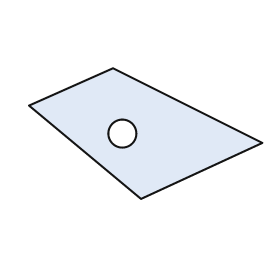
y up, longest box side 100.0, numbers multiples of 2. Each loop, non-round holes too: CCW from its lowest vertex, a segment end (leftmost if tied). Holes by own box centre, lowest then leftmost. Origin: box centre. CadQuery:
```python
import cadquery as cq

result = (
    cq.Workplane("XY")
    .moveTo(-2.0, -28.0)
    .lineTo(50.0, -4.0)
    .lineTo(-14.0, 28.0)
    .lineTo(-50.0, 12.0)
    .close()
    .moveTo(-10.0, 0.0)
    .circle(6.0)
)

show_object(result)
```